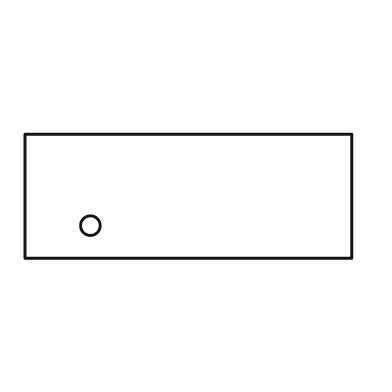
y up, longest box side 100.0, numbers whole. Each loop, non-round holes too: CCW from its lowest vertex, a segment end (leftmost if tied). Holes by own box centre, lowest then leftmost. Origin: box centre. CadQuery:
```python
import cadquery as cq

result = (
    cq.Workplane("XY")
    .moveTo(-50.0, -19.0)
    .lineTo(50.0, -19.0)
    .lineTo(50.0, 19.0)
    .lineTo(-50.0, 19.0)
    .close()
    .moveTo(-30.0, -9.0)
    .circle(3.0)
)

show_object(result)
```